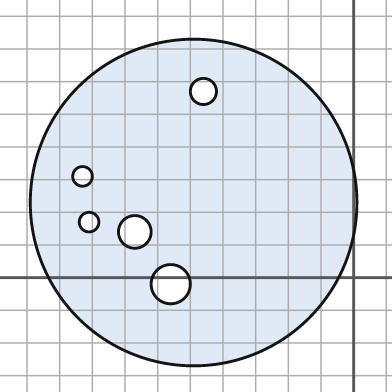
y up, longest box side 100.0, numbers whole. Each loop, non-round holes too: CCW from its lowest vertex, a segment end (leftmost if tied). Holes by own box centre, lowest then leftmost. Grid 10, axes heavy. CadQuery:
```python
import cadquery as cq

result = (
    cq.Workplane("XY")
    .moveTo(-49.0, 23.0)
    .circle(50.0)
    .moveTo(-56.0, -2.0)
    .circle(6.0)
    .moveTo(-67.0, 14.0)
    .circle(5.0)
    .moveTo(-81.0, 17.0)
    .circle(3.0)
    .moveTo(-83.0, 31.0)
    .circle(3.0)
    .moveTo(-46.0, 57.0)
    .circle(4.0)
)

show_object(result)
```